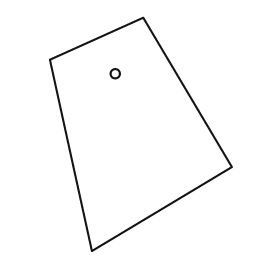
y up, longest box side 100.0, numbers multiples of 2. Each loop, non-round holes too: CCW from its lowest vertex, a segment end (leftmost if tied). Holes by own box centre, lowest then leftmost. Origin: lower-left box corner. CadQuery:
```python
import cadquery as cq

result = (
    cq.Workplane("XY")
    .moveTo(18.0, 0.0)
    .lineTo(78.0, 36.0)
    .lineTo(40.0, 100.0)
    .lineTo(0.0, 82.0)
    .close()
    .moveTo(28.0, 76.0)
    .circle(2.0)
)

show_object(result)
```